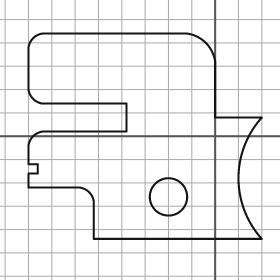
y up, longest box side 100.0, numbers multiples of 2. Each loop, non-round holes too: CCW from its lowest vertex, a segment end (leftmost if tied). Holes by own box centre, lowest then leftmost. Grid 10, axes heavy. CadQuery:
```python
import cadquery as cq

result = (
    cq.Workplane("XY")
    .moveTo(-52.0, -44.0)
    .lineTo(20.0, -44.0)
    .threePointArc((10.0, -18.0), (20.0, 8.0))
    .lineTo(0.0, 8.0)
    .lineTo(0.0, 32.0)
    .threePointArc((-4.0, 40.0), (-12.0, 44.0))
    .lineTo(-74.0, 44.0)
    .threePointArc((-78.0, 42.0), (-80.0, 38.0))
    .lineTo(-80.0, 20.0)
    .threePointArc((-78.0, 16.0), (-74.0, 14.0))
    .lineTo(-38.0, 14.0)
    .lineTo(-38.0, 2.0)
    .lineTo(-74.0, 2.0)
    .threePointArc((-78.0, 0.0), (-80.0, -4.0))
    .lineTo(-80.0, -12.0)
    .lineTo(-76.0, -12.0)
    .lineTo(-76.0, -16.0)
    .lineTo(-80.0, -16.0)
    .lineTo(-80.0, -22.0)
    .lineTo(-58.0, -22.0)
    .threePointArc((-54.0, -24.0), (-52.0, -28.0))
    .close()
    .moveTo(-20.0, -26.0)
    .circle(8.0)
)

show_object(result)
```